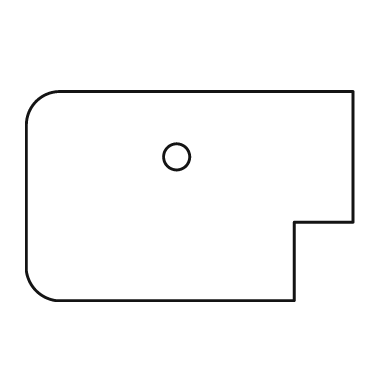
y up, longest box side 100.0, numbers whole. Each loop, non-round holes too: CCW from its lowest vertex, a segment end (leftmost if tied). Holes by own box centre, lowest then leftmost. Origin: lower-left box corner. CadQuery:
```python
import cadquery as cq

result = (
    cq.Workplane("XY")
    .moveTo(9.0, 0.0)
    .lineTo(82.0, 0.0)
    .lineTo(82.0, 24.0)
    .lineTo(100.0, 24.0)
    .lineTo(100.0, 64.0)
    .lineTo(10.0, 64.0)
    .threePointArc((3.0, 61.0), (0.0, 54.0))
    .lineTo(0.0, 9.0)
    .threePointArc((3.0, 3.0), (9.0, 0.0))
    .close()
    .moveTo(46.0, 44.0)
    .circle(4.0)
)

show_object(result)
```